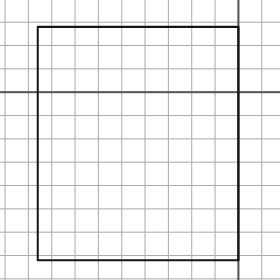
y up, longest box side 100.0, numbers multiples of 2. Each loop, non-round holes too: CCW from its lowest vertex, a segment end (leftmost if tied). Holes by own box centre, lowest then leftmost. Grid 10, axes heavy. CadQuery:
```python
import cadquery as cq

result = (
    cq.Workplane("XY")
    .moveTo(-86.0, -72.0)
    .lineTo(0.0, -72.0)
    .lineTo(0.0, 28.0)
    .lineTo(-86.0, 28.0)
    .close()
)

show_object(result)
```